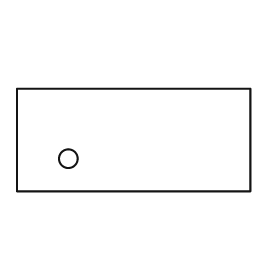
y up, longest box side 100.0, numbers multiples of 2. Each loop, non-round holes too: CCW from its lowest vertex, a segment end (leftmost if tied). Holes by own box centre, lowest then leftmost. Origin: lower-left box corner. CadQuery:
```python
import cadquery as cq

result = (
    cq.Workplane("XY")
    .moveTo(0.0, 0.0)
    .lineTo(100.0, 0.0)
    .lineTo(100.0, 44.0)
    .lineTo(0.0, 44.0)
    .close()
    .moveTo(22.0, 14.0)
    .circle(4.0)
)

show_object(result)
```